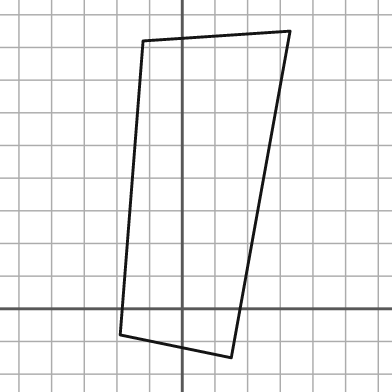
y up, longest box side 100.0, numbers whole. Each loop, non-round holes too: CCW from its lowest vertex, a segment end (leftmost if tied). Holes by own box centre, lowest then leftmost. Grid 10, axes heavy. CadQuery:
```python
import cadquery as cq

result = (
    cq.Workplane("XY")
    .moveTo(15.0, -15.0)
    .lineTo(33.0, 85.0)
    .lineTo(-12.0, 82.0)
    .lineTo(-19.0, -8.0)
    .close()
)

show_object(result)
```